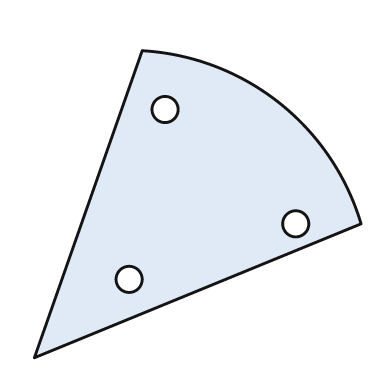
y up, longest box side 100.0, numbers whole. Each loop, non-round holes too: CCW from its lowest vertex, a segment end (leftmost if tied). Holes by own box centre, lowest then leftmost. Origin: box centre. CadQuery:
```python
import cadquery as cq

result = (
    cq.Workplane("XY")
    .moveTo(-50.0, -47.0)
    .lineTo(50.0, -6.0)
    .threePointArc((25.0, 31.0), (-17.0, 47.0))
    .close()
    .moveTo(-21.0, -23.0)
    .circle(4.0)
    .moveTo(30.0, -6.0)
    .circle(4.0)
    .moveTo(-10.0, 29.0)
    .circle(4.0)
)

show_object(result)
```